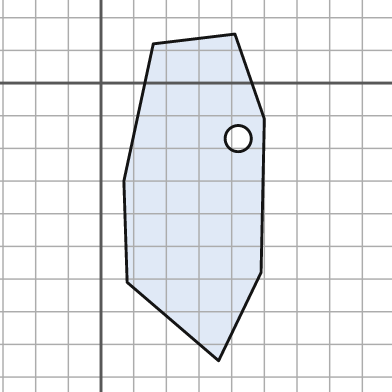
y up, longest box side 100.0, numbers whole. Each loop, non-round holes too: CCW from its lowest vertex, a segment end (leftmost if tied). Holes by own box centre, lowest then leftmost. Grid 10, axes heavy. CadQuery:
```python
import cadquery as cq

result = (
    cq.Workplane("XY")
    .moveTo(36.0, -85.0)
    .lineTo(49.0, -58.0)
    .lineTo(50.0, -11.0)
    .lineTo(41.0, 15.0)
    .lineTo(16.0, 12.0)
    .lineTo(7.0, -30.0)
    .lineTo(8.0, -61.0)
    .close()
    .moveTo(42.0, -17.0)
    .circle(4.0)
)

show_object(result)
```